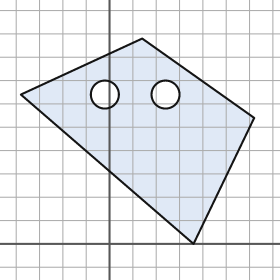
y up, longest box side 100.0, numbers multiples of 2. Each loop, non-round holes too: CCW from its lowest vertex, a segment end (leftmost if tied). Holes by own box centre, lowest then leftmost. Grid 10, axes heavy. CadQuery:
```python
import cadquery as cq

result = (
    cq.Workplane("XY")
    .moveTo(36.0, 0.0)
    .lineTo(62.0, 54.0)
    .lineTo(14.0, 88.0)
    .lineTo(-38.0, 64.0)
    .close()
    .moveTo(-2.0, 64.0)
    .circle(6.0)
    .moveTo(24.0, 64.0)
    .circle(6.0)
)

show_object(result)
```